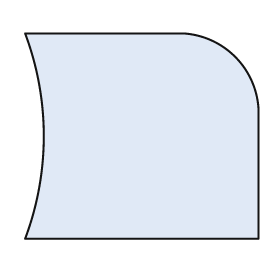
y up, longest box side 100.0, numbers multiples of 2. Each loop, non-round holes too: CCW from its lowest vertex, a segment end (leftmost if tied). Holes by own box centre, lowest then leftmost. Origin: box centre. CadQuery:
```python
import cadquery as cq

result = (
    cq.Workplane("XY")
    .moveTo(-50.0, -44.0)
    .lineTo(50.0, -44.0)
    .lineTo(50.0, 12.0)
    .threePointArc((40.0, 34.0), (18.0, 44.0))
    .lineTo(-50.0, 44.0)
    .threePointArc((-42.0, 0.0), (-50.0, -44.0))
    .close()
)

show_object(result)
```